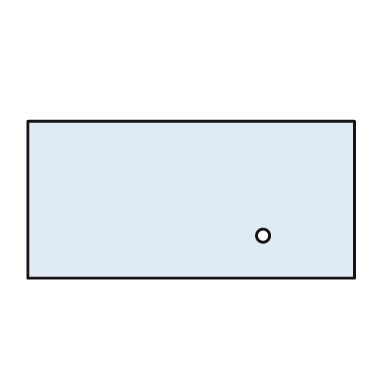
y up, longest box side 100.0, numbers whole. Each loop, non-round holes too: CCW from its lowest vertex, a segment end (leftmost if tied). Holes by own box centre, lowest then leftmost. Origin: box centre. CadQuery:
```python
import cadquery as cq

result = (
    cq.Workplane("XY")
    .moveTo(-50.0, -24.0)
    .lineTo(50.0, -24.0)
    .lineTo(50.0, 24.0)
    .lineTo(-50.0, 24.0)
    .close()
    .moveTo(22.0, -11.0)
    .circle(2.0)
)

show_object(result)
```